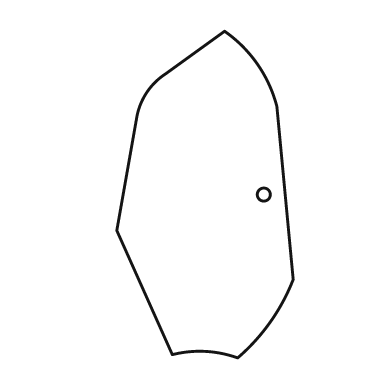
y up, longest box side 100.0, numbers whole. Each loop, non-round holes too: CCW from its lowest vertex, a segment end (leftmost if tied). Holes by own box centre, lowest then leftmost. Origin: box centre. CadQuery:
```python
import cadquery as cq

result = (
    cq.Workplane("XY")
    .moveTo(10.0, -50.0)
    .threePointArc((20.0, -39.0), (27.0, -26.0))
    .lineTo(22.0, 27.0)
    .threePointArc((16.0, 40.0), (6.0, 50.0))
    .lineTo(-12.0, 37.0)
    .threePointArc((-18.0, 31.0), (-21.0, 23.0))
    .lineTo(-27.0, -11.0)
    .lineTo(-10.0, -49.0)
    .threePointArc((0.0, -48.0), (10.0, -50.0))
    .close()
    .moveTo(18.0, 0.0)
    .circle(2.0)
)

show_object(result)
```